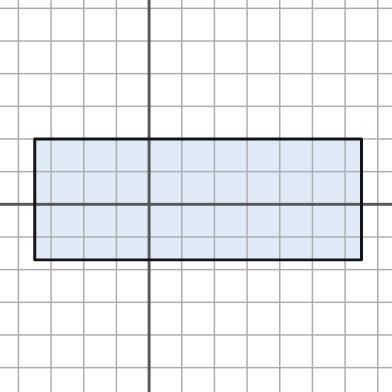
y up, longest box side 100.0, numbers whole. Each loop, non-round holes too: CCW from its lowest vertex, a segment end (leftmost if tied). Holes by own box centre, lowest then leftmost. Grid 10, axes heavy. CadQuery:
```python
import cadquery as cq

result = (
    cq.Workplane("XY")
    .moveTo(-35.0, -17.0)
    .lineTo(65.0, -17.0)
    .lineTo(65.0, 20.0)
    .lineTo(-35.0, 20.0)
    .close()
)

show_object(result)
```